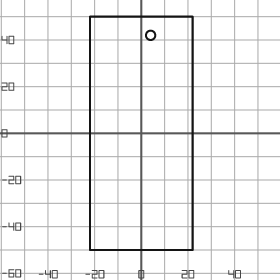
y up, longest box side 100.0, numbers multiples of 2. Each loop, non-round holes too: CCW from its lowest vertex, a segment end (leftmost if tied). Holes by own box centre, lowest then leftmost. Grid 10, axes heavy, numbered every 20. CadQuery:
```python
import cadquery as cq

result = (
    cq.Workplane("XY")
    .moveTo(-22.0, -50.0)
    .lineTo(22.0, -50.0)
    .lineTo(22.0, 50.0)
    .lineTo(-22.0, 50.0)
    .close()
    .moveTo(4.0, 42.0)
    .circle(2.0)
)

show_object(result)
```